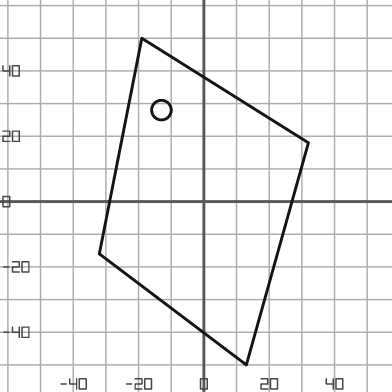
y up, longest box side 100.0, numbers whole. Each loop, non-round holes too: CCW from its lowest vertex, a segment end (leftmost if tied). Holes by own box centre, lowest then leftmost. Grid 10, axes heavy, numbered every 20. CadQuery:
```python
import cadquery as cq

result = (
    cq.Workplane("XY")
    .moveTo(13.0, -50.0)
    .lineTo(32.0, 18.0)
    .lineTo(-19.0, 50.0)
    .lineTo(-32.0, -16.0)
    .close()
    .moveTo(-13.0, 28.0)
    .circle(3.0)
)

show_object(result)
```